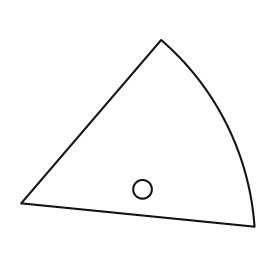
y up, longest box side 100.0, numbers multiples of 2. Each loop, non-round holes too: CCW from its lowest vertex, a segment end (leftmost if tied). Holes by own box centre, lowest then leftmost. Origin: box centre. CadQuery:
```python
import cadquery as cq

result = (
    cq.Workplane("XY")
    .moveTo(50.0, -40.0)
    .threePointArc((38.0, 4.0), (10.0, 40.0))
    .lineTo(-50.0, -30.0)
    .close()
    .moveTo(2.0, -24.0)
    .circle(4.0)
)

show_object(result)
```